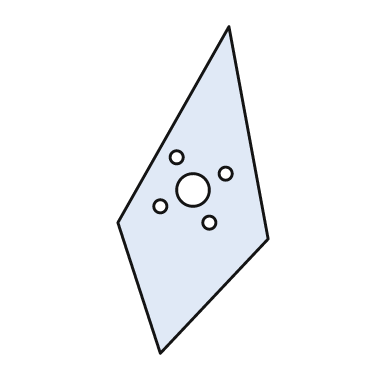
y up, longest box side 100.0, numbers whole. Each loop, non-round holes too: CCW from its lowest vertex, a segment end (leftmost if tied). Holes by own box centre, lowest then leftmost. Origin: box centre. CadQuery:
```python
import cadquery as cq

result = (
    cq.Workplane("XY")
    .moveTo(-10.0, -50.0)
    .lineTo(23.0, -15.0)
    .lineTo(11.0, 50.0)
    .lineTo(-23.0, -10.0)
    .close()
    .moveTo(5.0, -10.0)
    .circle(2.0)
    .moveTo(-10.0, -5.0)
    .circle(2.0)
    .moveTo(0.0, 0.0)
    .circle(5.0)
    .moveTo(10.0, 5.0)
    .circle(2.0)
    .moveTo(-5.0, 10.0)
    .circle(2.0)
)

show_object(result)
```